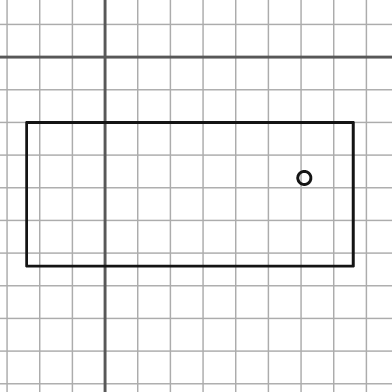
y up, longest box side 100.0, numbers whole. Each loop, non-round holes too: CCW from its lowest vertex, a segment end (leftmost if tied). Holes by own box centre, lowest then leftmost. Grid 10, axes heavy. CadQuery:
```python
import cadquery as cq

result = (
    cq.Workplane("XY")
    .moveTo(-24.0, -64.0)
    .lineTo(76.0, -64.0)
    .lineTo(76.0, -20.0)
    .lineTo(-24.0, -20.0)
    .close()
    .moveTo(61.0, -37.0)
    .circle(2.0)
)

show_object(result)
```